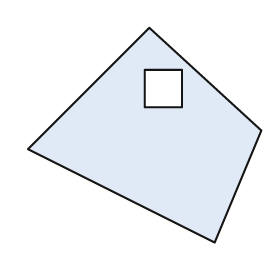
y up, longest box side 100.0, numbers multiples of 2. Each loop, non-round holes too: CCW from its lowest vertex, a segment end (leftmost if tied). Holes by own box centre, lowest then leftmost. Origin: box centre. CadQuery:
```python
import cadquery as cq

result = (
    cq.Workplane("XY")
    .moveTo(30.0, -46.0)
    .lineTo(50.0, 2.0)
    .lineTo(2.0, 46.0)
    .lineTo(-50.0, -6.0)
    .close()
    .moveTo(0.0, 12.0)
    .lineTo(16.0, 12.0)
    .lineTo(16.0, 28.0)
    .lineTo(0.0, 28.0)
    .close()
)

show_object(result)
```